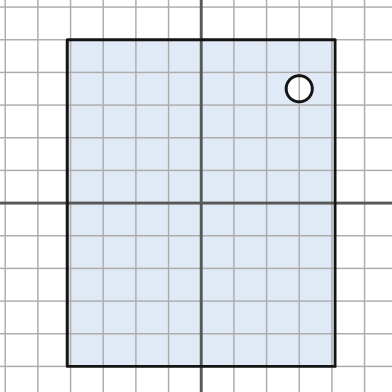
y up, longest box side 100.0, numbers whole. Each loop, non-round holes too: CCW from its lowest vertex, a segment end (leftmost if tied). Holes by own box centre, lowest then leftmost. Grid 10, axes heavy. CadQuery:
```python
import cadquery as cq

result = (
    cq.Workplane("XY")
    .moveTo(-41.0, -50.0)
    .lineTo(41.0, -50.0)
    .lineTo(41.0, 50.0)
    .lineTo(-41.0, 50.0)
    .close()
    .moveTo(30.0, 35.0)
    .circle(4.0)
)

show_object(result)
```